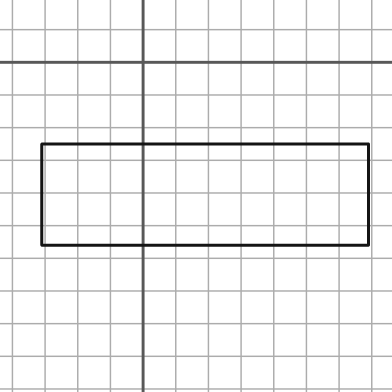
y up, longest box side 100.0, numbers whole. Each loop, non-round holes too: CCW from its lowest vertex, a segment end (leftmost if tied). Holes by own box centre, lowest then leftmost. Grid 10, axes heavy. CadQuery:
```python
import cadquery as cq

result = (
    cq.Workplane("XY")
    .moveTo(-31.0, -56.0)
    .lineTo(69.0, -56.0)
    .lineTo(69.0, -25.0)
    .lineTo(-31.0, -25.0)
    .close()
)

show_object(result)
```